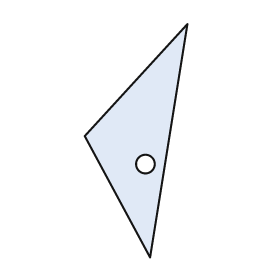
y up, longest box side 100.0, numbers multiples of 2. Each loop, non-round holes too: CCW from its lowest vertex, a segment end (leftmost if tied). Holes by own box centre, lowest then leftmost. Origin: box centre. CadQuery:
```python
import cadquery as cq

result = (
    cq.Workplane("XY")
    .moveTo(6.0, -50.0)
    .lineTo(22.0, 50.0)
    .lineTo(-22.0, 2.0)
    .close()
    .moveTo(4.0, -10.0)
    .circle(4.0)
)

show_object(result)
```